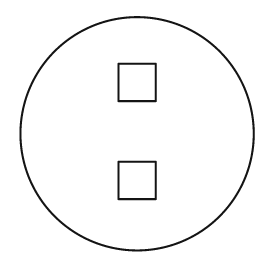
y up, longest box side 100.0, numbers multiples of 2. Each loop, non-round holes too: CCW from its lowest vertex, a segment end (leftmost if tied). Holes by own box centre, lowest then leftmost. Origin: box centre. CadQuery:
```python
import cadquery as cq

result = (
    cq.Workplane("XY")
    .moveTo(0.0, 0.0)
    .circle(50.0)
    .moveTo(-8.0, -28.0)
    .lineTo(8.0, -28.0)
    .lineTo(8.0, -12.0)
    .lineTo(-8.0, -12.0)
    .close()
    .moveTo(-8.0, 14.0)
    .lineTo(8.0, 14.0)
    .lineTo(8.0, 30.0)
    .lineTo(-8.0, 30.0)
    .close()
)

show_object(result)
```